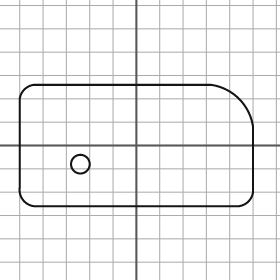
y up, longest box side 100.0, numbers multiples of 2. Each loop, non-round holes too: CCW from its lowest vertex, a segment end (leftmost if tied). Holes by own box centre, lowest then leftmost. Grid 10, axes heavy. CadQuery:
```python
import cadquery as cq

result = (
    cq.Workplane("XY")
    .moveTo(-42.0, -26.0)
    .lineTo(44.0, -26.0)
    .threePointArc((48.0, -24.0), (50.0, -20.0))
    .lineTo(50.0, 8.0)
    .threePointArc((44.0, 20.0), (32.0, 26.0))
    .lineTo(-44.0, 26.0)
    .threePointArc((-48.0, 24.0), (-50.0, 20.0))
    .lineTo(-50.0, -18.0)
    .threePointArc((-48.0, -24.0), (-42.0, -26.0))
    .close()
    .moveTo(-24.0, -8.0)
    .circle(4.0)
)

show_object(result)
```